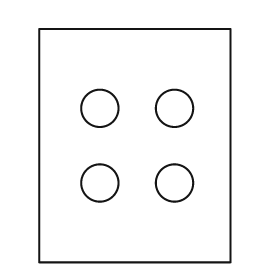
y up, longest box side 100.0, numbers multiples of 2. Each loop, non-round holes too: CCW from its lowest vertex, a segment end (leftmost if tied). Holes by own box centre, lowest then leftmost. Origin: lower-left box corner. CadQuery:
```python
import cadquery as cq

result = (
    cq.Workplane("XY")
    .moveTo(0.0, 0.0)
    .lineTo(82.0, 0.0)
    .lineTo(82.0, 100.0)
    .lineTo(0.0, 100.0)
    .close()
    .moveTo(26.0, 34.0)
    .circle(8.0)
    .moveTo(58.0, 34.0)
    .circle(8.0)
    .moveTo(26.0, 66.0)
    .circle(8.0)
    .moveTo(58.0, 66.0)
    .circle(8.0)
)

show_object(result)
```